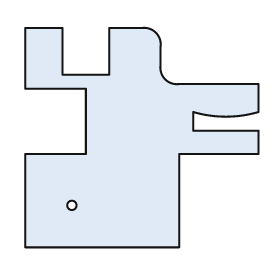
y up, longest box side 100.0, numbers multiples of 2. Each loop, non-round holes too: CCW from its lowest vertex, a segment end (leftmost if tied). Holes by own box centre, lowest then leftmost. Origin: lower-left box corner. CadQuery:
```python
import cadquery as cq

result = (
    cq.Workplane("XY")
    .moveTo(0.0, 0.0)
    .lineTo(66.0, 0.0)
    .lineTo(66.0, 40.0)
    .lineTo(100.0, 40.0)
    .lineTo(100.0, 50.0)
    .lineTo(72.0, 50.0)
    .lineTo(72.0, 58.0)
    .threePointArc((86.0, 56.0), (100.0, 58.0))
    .lineTo(100.0, 70.0)
    .lineTo(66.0, 70.0)
    .threePointArc((60.0, 72.0), (58.0, 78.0))
    .lineTo(58.0, 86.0)
    .threePointArc((56.0, 92.0), (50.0, 94.0))
    .lineTo(36.0, 94.0)
    .lineTo(36.0, 74.0)
    .lineTo(16.0, 74.0)
    .lineTo(16.0, 94.0)
    .lineTo(0.0, 94.0)
    .lineTo(0.0, 68.0)
    .lineTo(26.0, 68.0)
    .lineTo(26.0, 40.0)
    .lineTo(0.0, 40.0)
    .close()
    .moveTo(20.0, 18.0)
    .circle(2.0)
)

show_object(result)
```